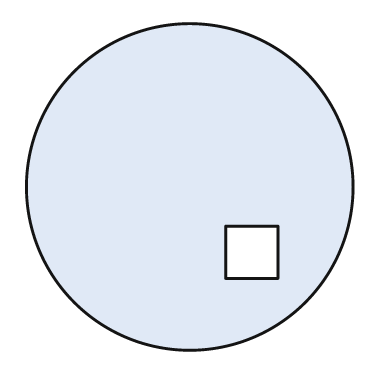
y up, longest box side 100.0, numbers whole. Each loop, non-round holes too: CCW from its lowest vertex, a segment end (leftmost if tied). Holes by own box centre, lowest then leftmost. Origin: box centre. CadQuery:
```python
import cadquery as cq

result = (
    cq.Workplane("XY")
    .moveTo(0.0, 0.0)
    .circle(50.0)
    .moveTo(11.0, -28.0)
    .lineTo(27.0, -28.0)
    .lineTo(27.0, -12.0)
    .lineTo(11.0, -12.0)
    .close()
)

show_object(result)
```